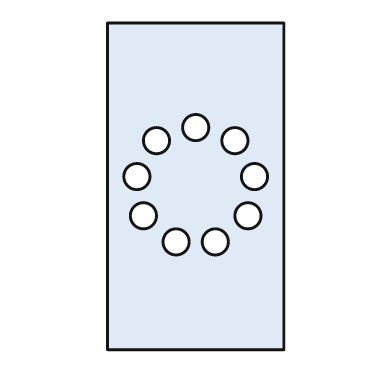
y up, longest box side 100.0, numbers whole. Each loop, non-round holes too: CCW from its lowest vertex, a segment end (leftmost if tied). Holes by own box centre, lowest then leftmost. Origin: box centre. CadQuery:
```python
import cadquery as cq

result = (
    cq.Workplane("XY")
    .moveTo(-27.0, -50.0)
    .lineTo(27.0, -50.0)
    .lineTo(27.0, 50.0)
    .lineTo(-27.0, 50.0)
    .close()
    .moveTo(-6.0, -17.0)
    .circle(4.0)
    .moveTo(6.0, -17.0)
    .circle(4.0)
    .moveTo(-16.0, -9.0)
    .circle(4.0)
    .moveTo(16.0, -9.0)
    .circle(4.0)
    .moveTo(-18.0, 3.0)
    .circle(4.0)
    .moveTo(18.0, 3.0)
    .circle(4.0)
    .moveTo(-12.0, 14.0)
    .circle(4.0)
    .moveTo(12.0, 14.0)
    .circle(4.0)
    .moveTo(0.0, 18.0)
    .circle(4.0)
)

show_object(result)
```